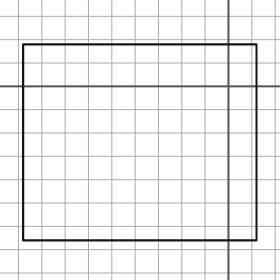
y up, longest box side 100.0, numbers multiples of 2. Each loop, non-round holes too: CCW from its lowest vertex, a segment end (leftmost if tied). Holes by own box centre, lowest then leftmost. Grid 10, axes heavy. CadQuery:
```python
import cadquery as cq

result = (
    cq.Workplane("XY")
    .moveTo(-88.0, -66.0)
    .lineTo(12.0, -66.0)
    .lineTo(12.0, 18.0)
    .lineTo(-88.0, 18.0)
    .close()
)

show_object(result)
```